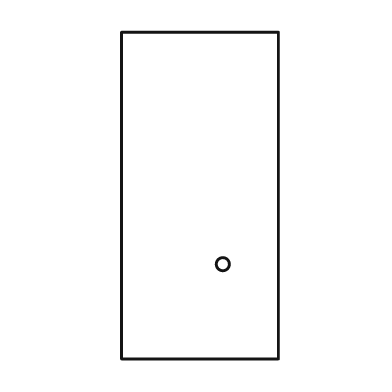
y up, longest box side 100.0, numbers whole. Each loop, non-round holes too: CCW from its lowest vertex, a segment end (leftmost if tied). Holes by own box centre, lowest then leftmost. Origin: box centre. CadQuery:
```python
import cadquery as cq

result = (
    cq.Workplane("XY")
    .moveTo(-24.0, -50.0)
    .lineTo(24.0, -50.0)
    .lineTo(24.0, 50.0)
    .lineTo(-24.0, 50.0)
    .close()
    .moveTo(7.0, -21.0)
    .circle(2.0)
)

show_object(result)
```